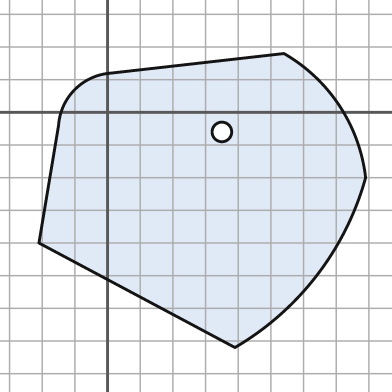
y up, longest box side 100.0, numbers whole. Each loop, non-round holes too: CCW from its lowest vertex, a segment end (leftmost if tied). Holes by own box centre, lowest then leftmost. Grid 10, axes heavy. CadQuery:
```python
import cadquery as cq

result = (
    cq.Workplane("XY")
    .moveTo(39.0, -72.0)
    .threePointArc((64.0, -50.0), (79.0, -20.0))
    .threePointArc((71.0, 2.0), (54.0, 18.0))
    .lineTo(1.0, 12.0)
    .threePointArc((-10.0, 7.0), (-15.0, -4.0))
    .lineTo(-21.0, -40.0)
    .close()
    .moveTo(35.0, -6.0)
    .circle(3.0)
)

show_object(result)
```